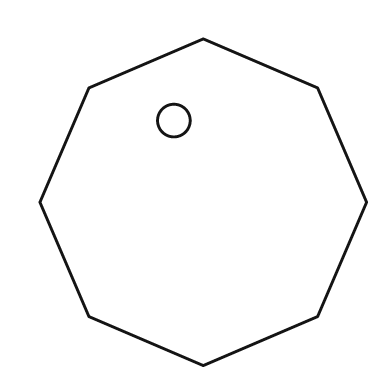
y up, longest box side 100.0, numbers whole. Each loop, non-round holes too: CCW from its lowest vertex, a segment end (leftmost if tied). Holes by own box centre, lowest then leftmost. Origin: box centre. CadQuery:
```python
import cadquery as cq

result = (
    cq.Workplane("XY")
    .moveTo(0.0, -50.0)
    .lineTo(35.0, -35.0)
    .lineTo(50.0, 0.0)
    .lineTo(35.0, 35.0)
    .lineTo(0.0, 50.0)
    .lineTo(-35.0, 35.0)
    .lineTo(-50.0, 0.0)
    .lineTo(-35.0, -35.0)
    .close()
    .moveTo(-9.0, 25.0)
    .circle(5.0)
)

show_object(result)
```